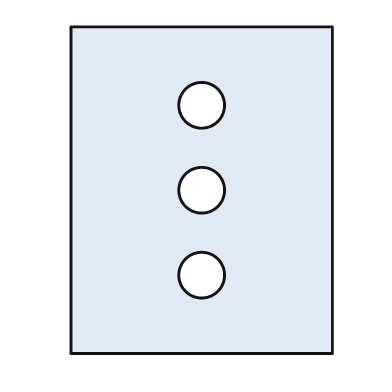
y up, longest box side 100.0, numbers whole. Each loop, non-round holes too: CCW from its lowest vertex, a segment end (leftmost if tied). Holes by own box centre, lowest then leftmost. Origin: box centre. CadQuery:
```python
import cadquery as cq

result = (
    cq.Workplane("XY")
    .moveTo(-40.0, -50.0)
    .lineTo(40.0, -50.0)
    .lineTo(40.0, 50.0)
    .lineTo(-40.0, 50.0)
    .close()
    .moveTo(0.0, -26.0)
    .circle(7.0)
    .moveTo(0.0, 0.0)
    .circle(7.0)
    .moveTo(0.0, 26.0)
    .circle(7.0)
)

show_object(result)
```